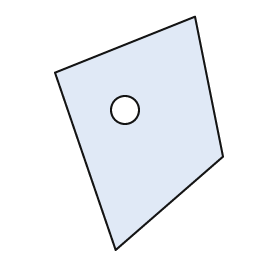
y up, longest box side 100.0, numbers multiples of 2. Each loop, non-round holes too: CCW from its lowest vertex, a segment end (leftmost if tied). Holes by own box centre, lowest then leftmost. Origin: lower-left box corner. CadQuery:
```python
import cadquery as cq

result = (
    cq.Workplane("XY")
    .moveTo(26.0, 0.0)
    .lineTo(72.0, 40.0)
    .lineTo(60.0, 100.0)
    .lineTo(0.0, 76.0)
    .close()
    .moveTo(30.0, 60.0)
    .circle(6.0)
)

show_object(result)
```